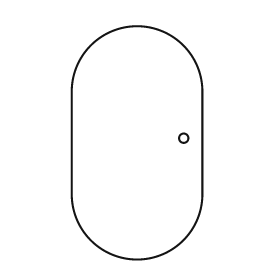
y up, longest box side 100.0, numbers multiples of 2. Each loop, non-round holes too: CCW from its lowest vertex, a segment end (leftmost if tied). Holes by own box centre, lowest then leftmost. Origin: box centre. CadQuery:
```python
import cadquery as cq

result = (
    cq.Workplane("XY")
    .moveTo(-28.0, -22.0)
    .threePointArc((0.0, -50.0), (28.0, -22.0))
    .lineTo(28.0, 22.0)
    .threePointArc((0.0, 50.0), (-28.0, 22.0))
    .close()
    .moveTo(20.0, 2.0)
    .circle(2.0)
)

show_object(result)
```